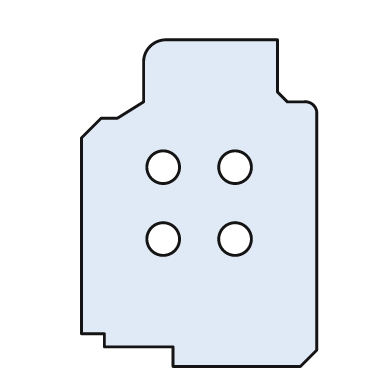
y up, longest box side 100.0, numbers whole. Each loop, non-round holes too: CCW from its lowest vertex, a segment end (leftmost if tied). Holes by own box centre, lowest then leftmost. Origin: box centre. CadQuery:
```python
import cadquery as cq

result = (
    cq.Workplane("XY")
    .moveTo(-8.0, -50.0)
    .lineTo(31.0, -50.0)
    .lineTo(36.0, -45.0)
    .lineTo(36.0, 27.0)
    .threePointArc((35.0, 30.0), (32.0, 31.0))
    .lineTo(27.0, 31.0)
    .lineTo(24.0, 34.0)
    .lineTo(24.0, 50.0)
    .lineTo(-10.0, 50.0)
    .threePointArc((-15.0, 48.0), (-17.0, 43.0))
    .lineTo(-17.0, 31.0)
    .lineTo(-25.0, 26.0)
    .lineTo(-30.0, 26.0)
    .lineTo(-36.0, 20.0)
    .lineTo(-36.0, -40.0)
    .lineTo(-29.0, -40.0)
    .lineTo(-29.0, -44.0)
    .lineTo(-8.0, -44.0)
    .close()
    .moveTo(-11.0, -11.0)
    .circle(5.0)
    .moveTo(11.0, -11.0)
    .circle(5.0)
    .moveTo(-11.0, 11.0)
    .circle(5.0)
    .moveTo(11.0, 11.0)
    .circle(5.0)
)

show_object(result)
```